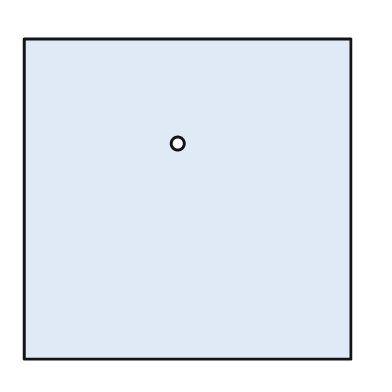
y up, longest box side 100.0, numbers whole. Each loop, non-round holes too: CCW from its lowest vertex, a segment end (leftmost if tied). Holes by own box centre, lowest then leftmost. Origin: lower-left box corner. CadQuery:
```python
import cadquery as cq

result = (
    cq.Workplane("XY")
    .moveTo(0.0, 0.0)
    .lineTo(100.0, 0.0)
    .lineTo(100.0, 98.0)
    .lineTo(0.0, 98.0)
    .close()
    .moveTo(47.0, 66.0)
    .circle(2.0)
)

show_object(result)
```